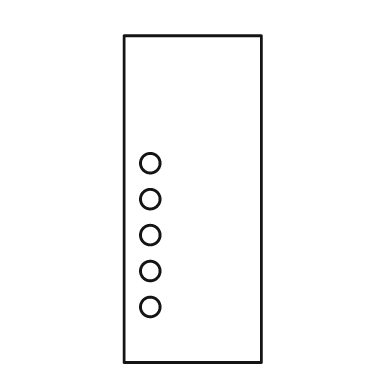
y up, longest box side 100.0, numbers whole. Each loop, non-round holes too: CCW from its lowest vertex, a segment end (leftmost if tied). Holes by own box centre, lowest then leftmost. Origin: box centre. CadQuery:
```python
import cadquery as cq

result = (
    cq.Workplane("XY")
    .moveTo(-21.0, -50.0)
    .lineTo(21.0, -50.0)
    .lineTo(21.0, 50.0)
    .lineTo(-21.0, 50.0)
    .close()
    .moveTo(-13.0, -33.0)
    .circle(3.0)
    .moveTo(-13.0, -22.0)
    .circle(3.0)
    .moveTo(-13.0, -11.0)
    .circle(3.0)
    .moveTo(-13.0, 0.0)
    .circle(3.0)
    .moveTo(-13.0, 11.0)
    .circle(3.0)
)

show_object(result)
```